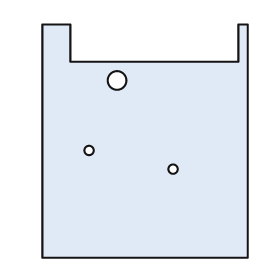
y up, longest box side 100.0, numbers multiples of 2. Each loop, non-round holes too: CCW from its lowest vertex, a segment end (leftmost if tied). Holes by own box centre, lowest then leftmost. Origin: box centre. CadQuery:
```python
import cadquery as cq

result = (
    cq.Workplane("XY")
    .moveTo(-44.0, -50.0)
    .lineTo(44.0, -50.0)
    .lineTo(44.0, 50.0)
    .lineTo(40.0, 50.0)
    .lineTo(40.0, 34.0)
    .lineTo(-32.0, 34.0)
    .lineTo(-32.0, 50.0)
    .lineTo(-44.0, 50.0)
    .close()
    .moveTo(12.0, -12.0)
    .circle(2.0)
    .moveTo(-24.0, -4.0)
    .circle(2.0)
    .moveTo(-12.0, 26.0)
    .circle(4.0)
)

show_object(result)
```